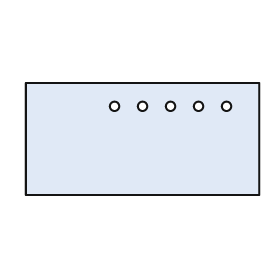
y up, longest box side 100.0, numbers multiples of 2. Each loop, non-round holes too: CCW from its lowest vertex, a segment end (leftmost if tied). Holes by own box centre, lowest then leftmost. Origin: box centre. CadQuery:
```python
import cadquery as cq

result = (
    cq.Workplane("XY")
    .moveTo(-50.0, -24.0)
    .lineTo(50.0, -24.0)
    .lineTo(50.0, 24.0)
    .lineTo(-50.0, 24.0)
    .close()
    .moveTo(-12.0, 14.0)
    .circle(2.0)
    .moveTo(0.0, 14.0)
    .circle(2.0)
    .moveTo(12.0, 14.0)
    .circle(2.0)
    .moveTo(24.0, 14.0)
    .circle(2.0)
    .moveTo(36.0, 14.0)
    .circle(2.0)
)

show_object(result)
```